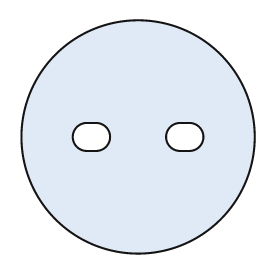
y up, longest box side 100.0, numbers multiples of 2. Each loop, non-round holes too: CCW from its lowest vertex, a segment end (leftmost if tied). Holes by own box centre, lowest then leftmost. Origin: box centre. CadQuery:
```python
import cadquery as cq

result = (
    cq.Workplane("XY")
    .moveTo(0.0, 0.0)
    .circle(50.0)
    .moveTo(-22.0, -6.0)
    .lineTo(-18.0, -6.0)
    .threePointArc((-12.0, 0.0), (-18.0, 6.0))
    .lineTo(-22.0, 6.0)
    .threePointArc((-28.0, 0.0), (-22.0, -6.0))
    .close()
    .moveTo(18.0, -6.0)
    .lineTo(22.0, -6.0)
    .threePointArc((28.0, 0.0), (22.0, 6.0))
    .lineTo(18.0, 6.0)
    .threePointArc((12.0, 0.0), (18.0, -6.0))
    .close()
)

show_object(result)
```